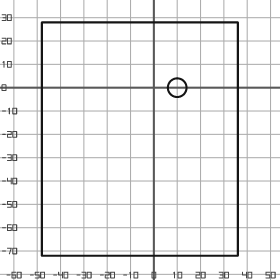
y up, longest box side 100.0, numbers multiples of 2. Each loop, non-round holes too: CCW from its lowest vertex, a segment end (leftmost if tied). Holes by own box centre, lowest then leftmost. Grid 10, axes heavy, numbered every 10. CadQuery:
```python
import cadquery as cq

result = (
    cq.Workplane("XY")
    .moveTo(-48.0, -72.0)
    .lineTo(36.0, -72.0)
    .lineTo(36.0, 28.0)
    .lineTo(-48.0, 28.0)
    .close()
    .moveTo(10.0, 0.0)
    .circle(4.0)
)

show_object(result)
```